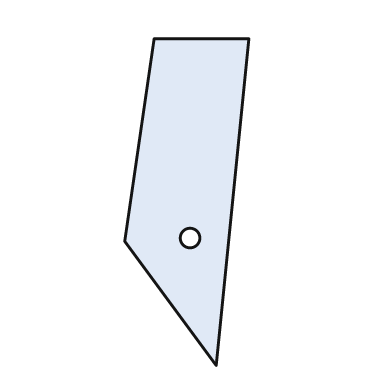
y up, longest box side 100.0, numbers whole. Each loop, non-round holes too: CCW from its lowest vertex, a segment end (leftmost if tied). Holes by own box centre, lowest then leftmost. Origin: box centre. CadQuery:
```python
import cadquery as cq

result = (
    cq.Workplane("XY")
    .moveTo(9.0, -50.0)
    .lineTo(19.0, 50.0)
    .lineTo(-10.0, 50.0)
    .lineTo(-19.0, -12.0)
    .close()
    .moveTo(1.0, -11.0)
    .circle(3.0)
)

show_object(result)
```